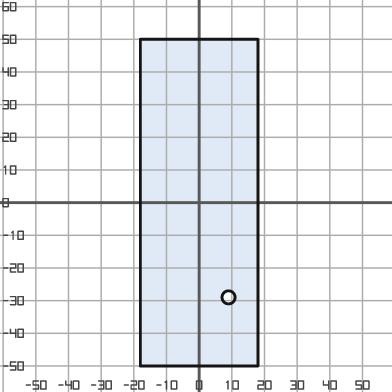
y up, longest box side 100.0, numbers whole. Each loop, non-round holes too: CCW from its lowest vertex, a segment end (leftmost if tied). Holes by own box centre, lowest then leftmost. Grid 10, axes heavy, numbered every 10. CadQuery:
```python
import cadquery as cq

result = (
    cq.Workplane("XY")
    .moveTo(-18.0, -50.0)
    .lineTo(18.0, -50.0)
    .lineTo(18.0, 50.0)
    .lineTo(-18.0, 50.0)
    .close()
    .moveTo(9.0, -29.0)
    .circle(2.0)
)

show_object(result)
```